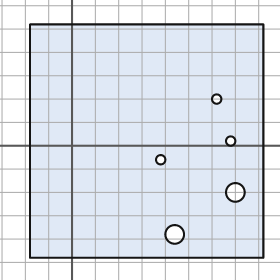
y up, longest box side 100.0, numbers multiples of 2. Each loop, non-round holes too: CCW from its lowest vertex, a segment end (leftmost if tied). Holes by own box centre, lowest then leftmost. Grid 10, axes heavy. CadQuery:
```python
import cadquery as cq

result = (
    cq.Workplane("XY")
    .moveTo(-18.0, -48.0)
    .lineTo(82.0, -48.0)
    .lineTo(82.0, 52.0)
    .lineTo(-18.0, 52.0)
    .close()
    .moveTo(44.0, -38.0)
    .circle(4.0)
    .moveTo(70.0, -20.0)
    .circle(4.0)
    .moveTo(38.0, -6.0)
    .circle(2.0)
    .moveTo(68.0, 2.0)
    .circle(2.0)
    .moveTo(62.0, 20.0)
    .circle(2.0)
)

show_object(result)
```